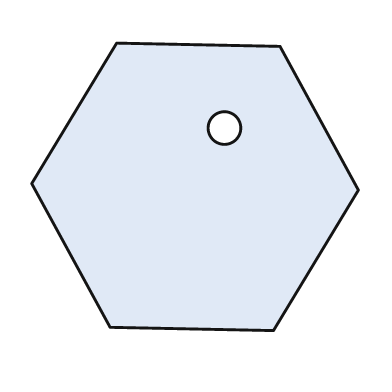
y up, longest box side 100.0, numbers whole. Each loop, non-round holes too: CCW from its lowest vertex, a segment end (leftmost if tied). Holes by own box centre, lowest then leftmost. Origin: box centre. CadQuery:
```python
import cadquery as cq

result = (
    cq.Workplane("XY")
    .moveTo(24.0, -44.0)
    .lineTo(50.0, -1.0)
    .lineTo(26.0, 43.0)
    .lineTo(-24.0, 44.0)
    .lineTo(-50.0, 1.0)
    .lineTo(-26.0, -43.0)
    .close()
    .moveTo(9.0, 18.0)
    .circle(5.0)
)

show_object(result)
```